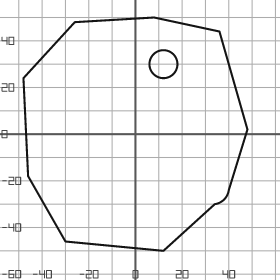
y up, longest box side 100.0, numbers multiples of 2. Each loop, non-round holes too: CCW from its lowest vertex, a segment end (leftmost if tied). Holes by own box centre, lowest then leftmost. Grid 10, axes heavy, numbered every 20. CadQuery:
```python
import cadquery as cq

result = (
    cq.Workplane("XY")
    .moveTo(12.0, -50.0)
    .lineTo(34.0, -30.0)
    .threePointArc((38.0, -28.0), (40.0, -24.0))
    .lineTo(48.0, 2.0)
    .lineTo(36.0, 44.0)
    .lineTo(8.0, 50.0)
    .lineTo(-26.0, 48.0)
    .lineTo(-48.0, 24.0)
    .lineTo(-46.0, -18.0)
    .lineTo(-30.0, -46.0)
    .close()
    .moveTo(12.0, 30.0)
    .circle(6.0)
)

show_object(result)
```